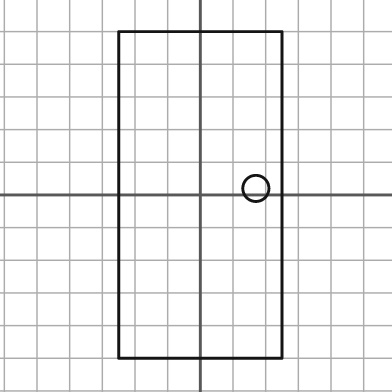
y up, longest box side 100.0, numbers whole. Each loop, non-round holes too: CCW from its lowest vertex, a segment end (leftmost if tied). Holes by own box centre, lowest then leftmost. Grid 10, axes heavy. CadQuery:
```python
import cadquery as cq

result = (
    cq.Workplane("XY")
    .moveTo(-25.0, -50.0)
    .lineTo(25.0, -50.0)
    .lineTo(25.0, 50.0)
    .lineTo(-25.0, 50.0)
    .close()
    .moveTo(17.0, 2.0)
    .circle(4.0)
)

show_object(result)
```